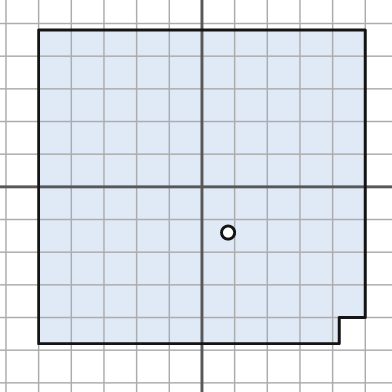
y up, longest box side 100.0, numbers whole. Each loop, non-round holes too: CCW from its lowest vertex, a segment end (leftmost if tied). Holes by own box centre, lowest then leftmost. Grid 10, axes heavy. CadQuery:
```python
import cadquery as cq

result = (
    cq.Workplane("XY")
    .moveTo(-50.0, -48.0)
    .lineTo(42.0, -48.0)
    .lineTo(42.0, -40.0)
    .lineTo(50.0, -40.0)
    .lineTo(50.0, 48.0)
    .lineTo(-50.0, 48.0)
    .close()
    .moveTo(8.0, -14.0)
    .circle(2.0)
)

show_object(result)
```